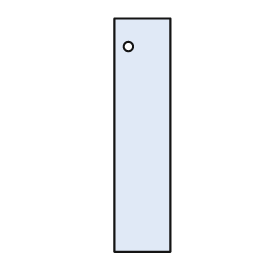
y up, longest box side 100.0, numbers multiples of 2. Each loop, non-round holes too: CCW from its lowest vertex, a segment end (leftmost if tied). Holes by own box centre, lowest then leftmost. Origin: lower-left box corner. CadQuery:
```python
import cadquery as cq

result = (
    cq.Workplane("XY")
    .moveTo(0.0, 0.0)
    .lineTo(24.0, 0.0)
    .lineTo(24.0, 100.0)
    .lineTo(0.0, 100.0)
    .close()
    .moveTo(6.0, 88.0)
    .circle(2.0)
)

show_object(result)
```